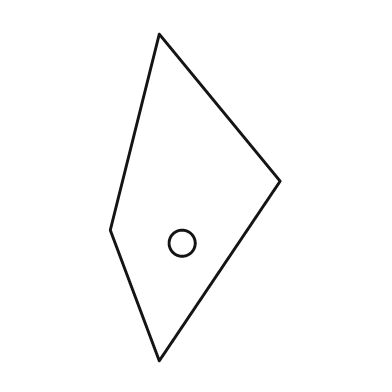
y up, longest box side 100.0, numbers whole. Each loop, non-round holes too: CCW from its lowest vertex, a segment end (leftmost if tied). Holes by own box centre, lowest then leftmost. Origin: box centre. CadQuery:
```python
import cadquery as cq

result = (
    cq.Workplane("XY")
    .moveTo(-11.0, -50.0)
    .lineTo(26.0, 5.0)
    .lineTo(-11.0, 50.0)
    .lineTo(-26.0, -10.0)
    .close()
    .moveTo(-4.0, -14.0)
    .circle(4.0)
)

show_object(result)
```